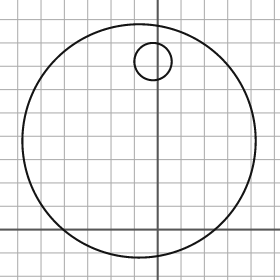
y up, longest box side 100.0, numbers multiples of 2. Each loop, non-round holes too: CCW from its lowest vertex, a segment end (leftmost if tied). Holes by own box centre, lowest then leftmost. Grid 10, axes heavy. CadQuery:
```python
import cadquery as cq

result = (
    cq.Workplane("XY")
    .moveTo(-8.0, 38.0)
    .circle(50.0)
    .moveTo(-2.0, 72.0)
    .circle(8.0)
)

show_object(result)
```